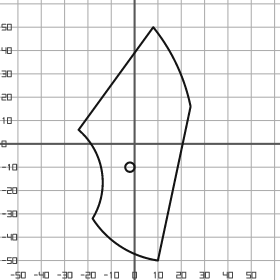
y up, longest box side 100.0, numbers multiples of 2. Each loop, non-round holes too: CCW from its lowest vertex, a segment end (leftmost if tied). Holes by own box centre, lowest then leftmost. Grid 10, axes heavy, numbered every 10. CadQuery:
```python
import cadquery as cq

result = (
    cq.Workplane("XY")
    .moveTo(10.0, -50.0)
    .lineTo(24.0, 16.0)
    .threePointArc((18.0, 34.0), (8.0, 50.0))
    .lineTo(-24.0, 6.0)
    .threePointArc((-14.0, -12.0), (-18.0, -32.0))
    .threePointArc((-6.0, -44.0), (10.0, -50.0))
    .close()
    .moveTo(-2.0, -10.0)
    .circle(2.0)
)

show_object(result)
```